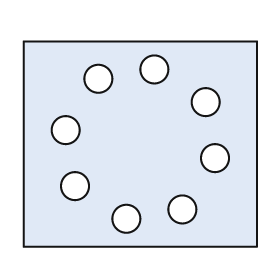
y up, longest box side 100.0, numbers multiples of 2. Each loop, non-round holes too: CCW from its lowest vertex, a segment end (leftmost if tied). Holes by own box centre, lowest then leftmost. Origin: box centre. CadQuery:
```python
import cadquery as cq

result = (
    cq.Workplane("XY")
    .moveTo(-50.0, -44.0)
    .lineTo(50.0, -44.0)
    .lineTo(50.0, 44.0)
    .lineTo(-50.0, 44.0)
    .close()
    .moveTo(-6.0, -32.0)
    .circle(6.0)
    .moveTo(18.0, -28.0)
    .circle(6.0)
    .moveTo(-28.0, -18.0)
    .circle(6.0)
    .moveTo(32.0, -6.0)
    .circle(6.0)
    .moveTo(-32.0, 6.0)
    .circle(6.0)
    .moveTo(28.0, 18.0)
    .circle(6.0)
    .moveTo(-18.0, 28.0)
    .circle(6.0)
    .moveTo(6.0, 32.0)
    .circle(6.0)
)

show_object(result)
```